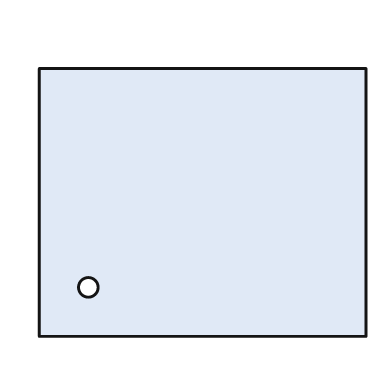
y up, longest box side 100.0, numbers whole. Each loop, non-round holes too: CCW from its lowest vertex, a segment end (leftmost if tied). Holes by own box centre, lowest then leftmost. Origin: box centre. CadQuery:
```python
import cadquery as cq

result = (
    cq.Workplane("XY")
    .moveTo(-50.0, -41.0)
    .lineTo(50.0, -41.0)
    .lineTo(50.0, 41.0)
    .lineTo(-50.0, 41.0)
    .close()
    .moveTo(-35.0, -26.0)
    .circle(3.0)
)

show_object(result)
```